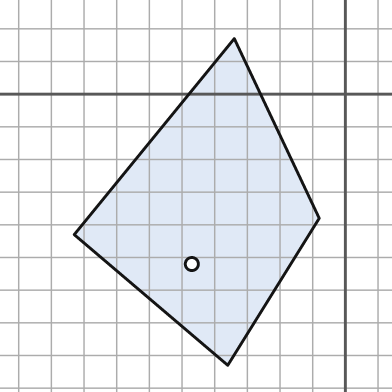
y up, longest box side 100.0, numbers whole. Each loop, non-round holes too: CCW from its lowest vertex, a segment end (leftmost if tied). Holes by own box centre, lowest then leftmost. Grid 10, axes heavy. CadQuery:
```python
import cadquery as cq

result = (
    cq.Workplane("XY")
    .moveTo(-36.0, -83.0)
    .lineTo(-8.0, -38.0)
    .lineTo(-34.0, 17.0)
    .lineTo(-83.0, -43.0)
    .close()
    .moveTo(-47.0, -52.0)
    .circle(2.0)
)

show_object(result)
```